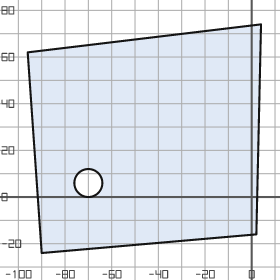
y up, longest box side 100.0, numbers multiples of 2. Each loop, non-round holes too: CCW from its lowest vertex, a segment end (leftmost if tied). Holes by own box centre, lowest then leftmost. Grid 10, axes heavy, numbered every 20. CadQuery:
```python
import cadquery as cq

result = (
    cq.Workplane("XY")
    .moveTo(-90.0, -24.0)
    .lineTo(2.0, -16.0)
    .lineTo(4.0, 74.0)
    .lineTo(-96.0, 62.0)
    .close()
    .moveTo(-70.0, 6.0)
    .circle(6.0)
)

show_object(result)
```